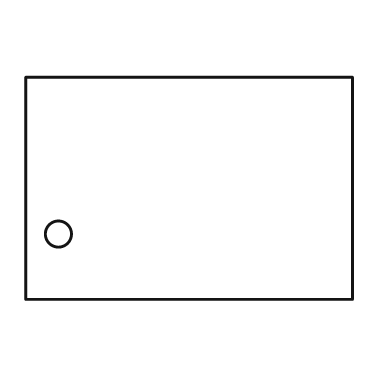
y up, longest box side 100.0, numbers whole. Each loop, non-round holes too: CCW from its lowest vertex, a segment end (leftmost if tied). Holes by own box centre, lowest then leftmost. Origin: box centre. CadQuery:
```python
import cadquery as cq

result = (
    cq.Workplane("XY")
    .moveTo(-50.0, -34.0)
    .lineTo(50.0, -34.0)
    .lineTo(50.0, 34.0)
    .lineTo(-50.0, 34.0)
    .close()
    .moveTo(-40.0, -14.0)
    .circle(4.0)
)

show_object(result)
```